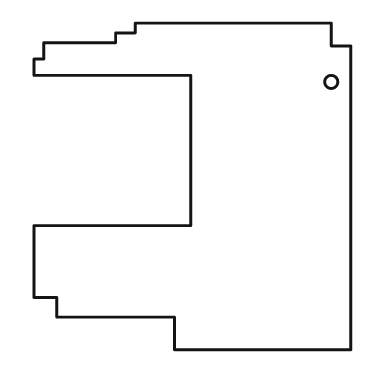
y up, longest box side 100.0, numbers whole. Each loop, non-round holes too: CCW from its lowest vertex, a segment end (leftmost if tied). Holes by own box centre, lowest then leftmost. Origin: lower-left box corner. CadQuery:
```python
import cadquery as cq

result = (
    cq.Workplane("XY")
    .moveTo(43.0, 0.0)
    .lineTo(97.0, 0.0)
    .lineTo(97.0, 93.0)
    .lineTo(91.0, 93.0)
    .lineTo(91.0, 100.0)
    .lineTo(31.0, 100.0)
    .lineTo(31.0, 97.0)
    .lineTo(25.0, 97.0)
    .lineTo(25.0, 94.0)
    .lineTo(3.0, 94.0)
    .lineTo(3.0, 89.0)
    .lineTo(0.0, 89.0)
    .lineTo(0.0, 84.0)
    .lineTo(48.0, 84.0)
    .lineTo(48.0, 38.0)
    .lineTo(0.0, 38.0)
    .lineTo(0.0, 16.0)
    .lineTo(7.0, 16.0)
    .lineTo(7.0, 10.0)
    .lineTo(43.0, 10.0)
    .close()
    .moveTo(91.0, 82.0)
    .circle(2.0)
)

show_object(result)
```